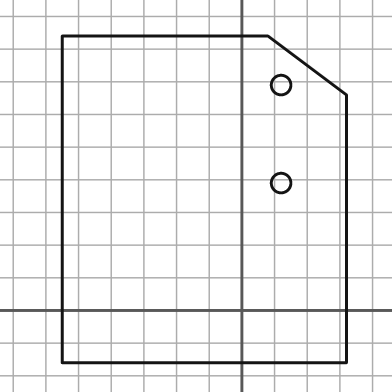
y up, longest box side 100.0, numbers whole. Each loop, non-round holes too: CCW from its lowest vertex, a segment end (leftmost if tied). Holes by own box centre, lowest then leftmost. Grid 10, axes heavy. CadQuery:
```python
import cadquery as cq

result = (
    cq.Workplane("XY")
    .moveTo(-55.0, -16.0)
    .lineTo(32.0, -16.0)
    .lineTo(32.0, 66.0)
    .lineTo(8.0, 84.0)
    .lineTo(-55.0, 84.0)
    .close()
    .moveTo(12.0, 39.0)
    .circle(3.0)
    .moveTo(12.0, 69.0)
    .circle(3.0)
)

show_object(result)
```